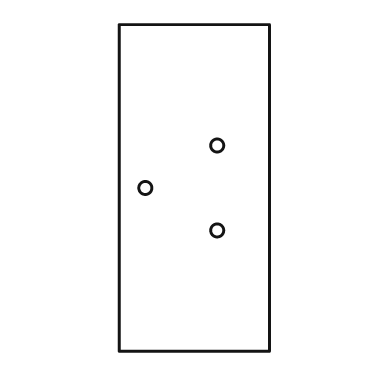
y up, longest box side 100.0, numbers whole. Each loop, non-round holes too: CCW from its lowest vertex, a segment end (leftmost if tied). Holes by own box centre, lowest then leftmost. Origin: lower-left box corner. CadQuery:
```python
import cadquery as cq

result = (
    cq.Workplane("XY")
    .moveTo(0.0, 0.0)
    .lineTo(46.0, 0.0)
    .lineTo(46.0, 100.0)
    .lineTo(0.0, 100.0)
    .close()
    .moveTo(30.0, 37.0)
    .circle(2.0)
    .moveTo(8.0, 50.0)
    .circle(2.0)
    .moveTo(30.0, 63.0)
    .circle(2.0)
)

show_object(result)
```